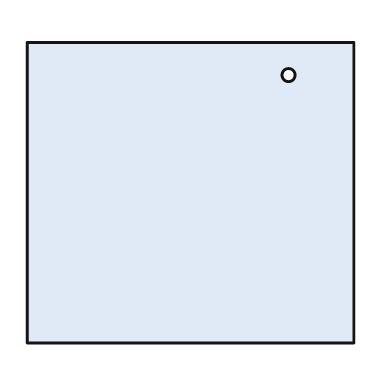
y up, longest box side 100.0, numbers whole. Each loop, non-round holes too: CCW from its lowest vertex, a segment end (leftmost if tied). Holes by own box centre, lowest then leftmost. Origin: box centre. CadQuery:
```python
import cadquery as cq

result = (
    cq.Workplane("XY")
    .moveTo(-50.0, -46.0)
    .lineTo(50.0, -46.0)
    .lineTo(50.0, 46.0)
    .lineTo(-50.0, 46.0)
    .close()
    .moveTo(30.0, 36.0)
    .circle(2.0)
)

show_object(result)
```